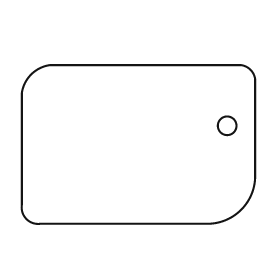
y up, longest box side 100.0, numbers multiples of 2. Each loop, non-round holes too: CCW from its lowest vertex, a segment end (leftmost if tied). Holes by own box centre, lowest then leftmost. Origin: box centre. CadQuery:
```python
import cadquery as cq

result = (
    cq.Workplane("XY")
    .moveTo(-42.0, -34.0)
    .lineTo(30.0, -34.0)
    .threePointArc((44.0, -28.0), (50.0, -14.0))
    .lineTo(50.0, 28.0)
    .threePointArc((48.0, 32.0), (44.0, 34.0))
    .lineTo(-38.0, 34.0)
    .threePointArc((-46.0, 30.0), (-50.0, 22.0))
    .lineTo(-50.0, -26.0)
    .threePointArc((-48.0, -32.0), (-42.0, -34.0))
    .close()
    .moveTo(38.0, 8.0)
    .circle(4.0)
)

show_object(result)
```